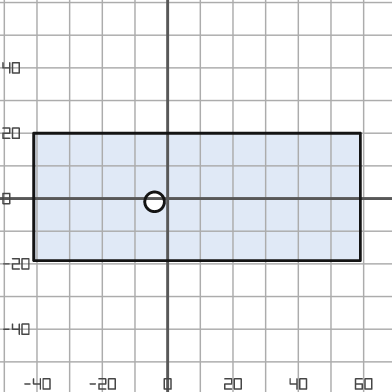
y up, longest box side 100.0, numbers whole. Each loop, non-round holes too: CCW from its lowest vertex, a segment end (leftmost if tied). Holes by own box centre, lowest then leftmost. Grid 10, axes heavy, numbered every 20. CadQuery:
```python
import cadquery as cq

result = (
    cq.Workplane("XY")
    .moveTo(-41.0, -19.0)
    .lineTo(59.0, -19.0)
    .lineTo(59.0, 20.0)
    .lineTo(-41.0, 20.0)
    .close()
    .moveTo(-4.0, -1.0)
    .circle(3.0)
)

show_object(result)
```